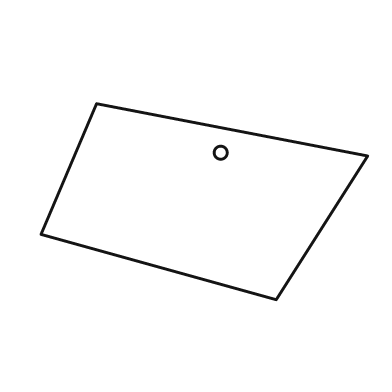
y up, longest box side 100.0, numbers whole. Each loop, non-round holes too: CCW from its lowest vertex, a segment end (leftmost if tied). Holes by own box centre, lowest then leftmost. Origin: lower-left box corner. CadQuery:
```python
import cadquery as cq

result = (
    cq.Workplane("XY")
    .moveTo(72.0, 0.0)
    .lineTo(100.0, 44.0)
    .lineTo(17.0, 60.0)
    .lineTo(0.0, 20.0)
    .close()
    .moveTo(55.0, 45.0)
    .circle(2.0)
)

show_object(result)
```